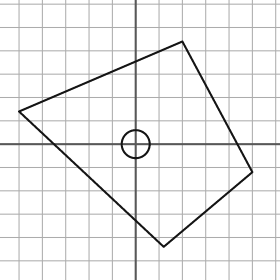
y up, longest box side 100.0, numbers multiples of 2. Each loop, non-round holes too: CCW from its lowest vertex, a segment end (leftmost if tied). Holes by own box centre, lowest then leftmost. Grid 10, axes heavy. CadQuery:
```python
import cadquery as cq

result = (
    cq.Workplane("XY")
    .moveTo(12.0, -44.0)
    .lineTo(50.0, -12.0)
    .lineTo(20.0, 44.0)
    .lineTo(-50.0, 14.0)
    .close()
    .moveTo(0.0, 0.0)
    .circle(6.0)
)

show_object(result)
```